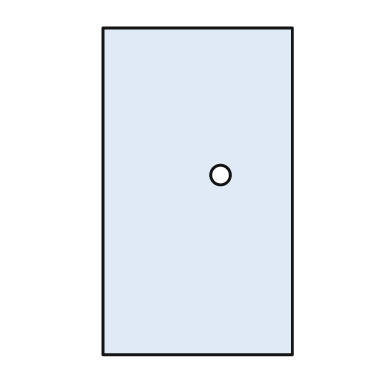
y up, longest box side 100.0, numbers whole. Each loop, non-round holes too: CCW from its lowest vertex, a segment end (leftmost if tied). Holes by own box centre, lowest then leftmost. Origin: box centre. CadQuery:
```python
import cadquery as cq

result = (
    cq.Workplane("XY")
    .moveTo(-29.0, -50.0)
    .lineTo(29.0, -50.0)
    .lineTo(29.0, 50.0)
    .lineTo(-29.0, 50.0)
    .close()
    .moveTo(7.0, 5.0)
    .circle(3.0)
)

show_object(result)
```